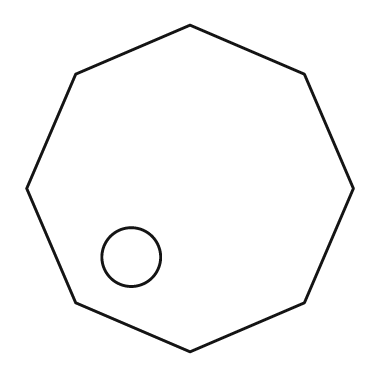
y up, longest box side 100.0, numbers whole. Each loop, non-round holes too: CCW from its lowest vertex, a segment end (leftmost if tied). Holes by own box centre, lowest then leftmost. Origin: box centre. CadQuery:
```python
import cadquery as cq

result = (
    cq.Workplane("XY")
    .moveTo(0.0, -50.0)
    .lineTo(35.0, -35.0)
    .lineTo(50.0, 0.0)
    .lineTo(35.0, 35.0)
    .lineTo(0.0, 50.0)
    .lineTo(-35.0, 35.0)
    .lineTo(-50.0, 0.0)
    .lineTo(-35.0, -35.0)
    .close()
    .moveTo(-18.0, -21.0)
    .circle(9.0)
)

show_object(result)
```